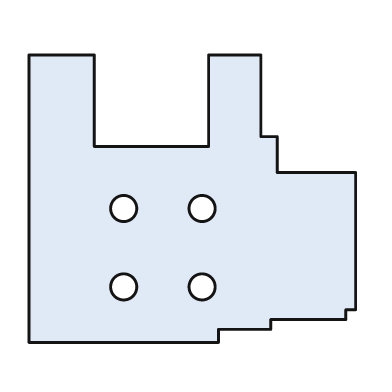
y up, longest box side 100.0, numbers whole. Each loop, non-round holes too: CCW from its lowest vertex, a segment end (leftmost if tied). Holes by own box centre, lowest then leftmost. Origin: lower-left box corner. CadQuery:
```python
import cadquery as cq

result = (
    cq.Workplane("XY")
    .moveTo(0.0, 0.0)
    .lineTo(58.0, 0.0)
    .lineTo(58.0, 4.0)
    .lineTo(74.0, 4.0)
    .lineTo(74.0, 7.0)
    .lineTo(97.0, 7.0)
    .lineTo(97.0, 10.0)
    .lineTo(100.0, 10.0)
    .lineTo(100.0, 52.0)
    .lineTo(76.0, 52.0)
    .lineTo(76.0, 63.0)
    .lineTo(71.0, 63.0)
    .lineTo(71.0, 88.0)
    .lineTo(55.0, 88.0)
    .lineTo(55.0, 60.0)
    .lineTo(20.0, 60.0)
    .lineTo(20.0, 88.0)
    .lineTo(0.0, 88.0)
    .close()
    .moveTo(29.0, 17.0)
    .circle(4.0)
    .moveTo(53.0, 17.0)
    .circle(4.0)
    .moveTo(29.0, 41.0)
    .circle(4.0)
    .moveTo(53.0, 41.0)
    .circle(4.0)
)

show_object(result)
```